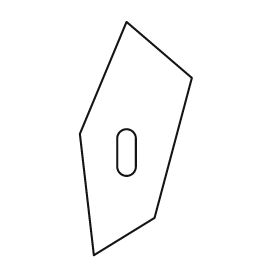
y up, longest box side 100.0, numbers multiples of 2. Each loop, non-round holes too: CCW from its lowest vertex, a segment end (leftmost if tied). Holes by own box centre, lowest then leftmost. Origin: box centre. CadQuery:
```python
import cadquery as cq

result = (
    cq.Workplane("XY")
    .moveTo(-18.0, -50.0)
    .lineTo(8.0, -34.0)
    .lineTo(24.0, 26.0)
    .lineTo(-4.0, 50.0)
    .lineTo(-24.0, 2.0)
    .close()
    .moveTo(-8.0, -12.0)
    .threePointArc((-4.0, -16.0), (0.0, -12.0))
    .lineTo(0.0, 0.0)
    .threePointArc((-4.0, 4.0), (-8.0, 0.0))
    .close()
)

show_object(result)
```